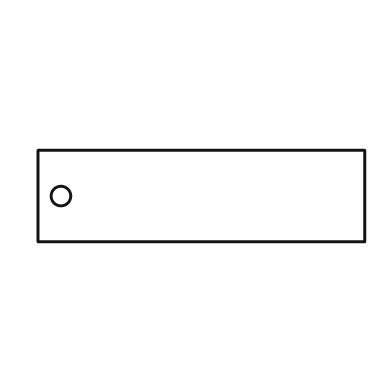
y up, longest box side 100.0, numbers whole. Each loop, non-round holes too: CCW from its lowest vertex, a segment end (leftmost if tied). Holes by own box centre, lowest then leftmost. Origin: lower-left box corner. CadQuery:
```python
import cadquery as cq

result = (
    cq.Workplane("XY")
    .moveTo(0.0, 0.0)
    .lineTo(100.0, 0.0)
    .lineTo(100.0, 28.0)
    .lineTo(0.0, 28.0)
    .close()
    .moveTo(7.0, 14.0)
    .circle(3.0)
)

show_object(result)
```